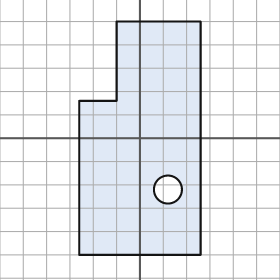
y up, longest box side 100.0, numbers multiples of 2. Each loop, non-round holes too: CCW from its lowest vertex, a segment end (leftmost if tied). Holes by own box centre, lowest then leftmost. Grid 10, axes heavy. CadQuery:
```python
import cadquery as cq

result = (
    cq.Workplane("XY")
    .moveTo(-26.0, -50.0)
    .lineTo(26.0, -50.0)
    .lineTo(26.0, 50.0)
    .lineTo(-10.0, 50.0)
    .lineTo(-10.0, 16.0)
    .lineTo(-26.0, 16.0)
    .close()
    .moveTo(12.0, -22.0)
    .circle(6.0)
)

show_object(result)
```